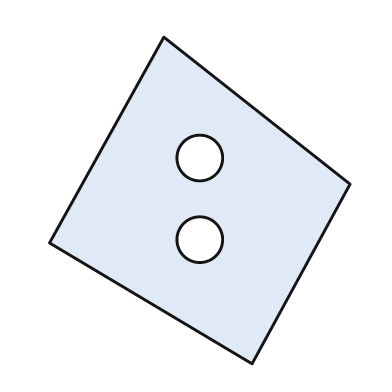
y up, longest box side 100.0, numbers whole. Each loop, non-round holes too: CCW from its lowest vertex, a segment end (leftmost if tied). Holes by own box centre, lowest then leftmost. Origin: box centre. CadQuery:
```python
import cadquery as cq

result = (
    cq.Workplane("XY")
    .moveTo(16.0, -50.0)
    .lineTo(46.0, 5.0)
    .lineTo(-11.0, 50.0)
    .lineTo(-46.0, -13.0)
    .close()
    .moveTo(0.0, -12.0)
    .circle(7.0)
    .moveTo(0.0, 13.0)
    .circle(7.0)
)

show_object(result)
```